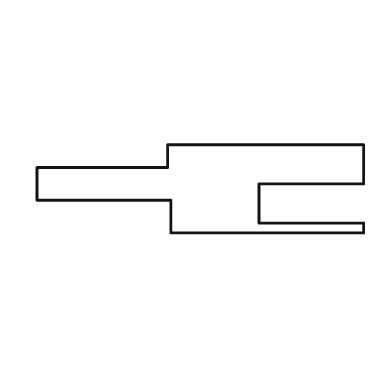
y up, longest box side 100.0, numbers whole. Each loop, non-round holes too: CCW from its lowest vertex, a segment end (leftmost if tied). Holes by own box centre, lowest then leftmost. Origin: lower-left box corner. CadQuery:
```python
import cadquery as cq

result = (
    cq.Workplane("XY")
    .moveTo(41.0, 0.0)
    .lineTo(100.0, 0.0)
    .lineTo(100.0, 3.0)
    .lineTo(68.0, 3.0)
    .lineTo(68.0, 15.0)
    .lineTo(100.0, 15.0)
    .lineTo(100.0, 27.0)
    .lineTo(40.0, 27.0)
    .lineTo(40.0, 20.0)
    .lineTo(0.0, 20.0)
    .lineTo(0.0, 10.0)
    .lineTo(41.0, 10.0)
    .close()
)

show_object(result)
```